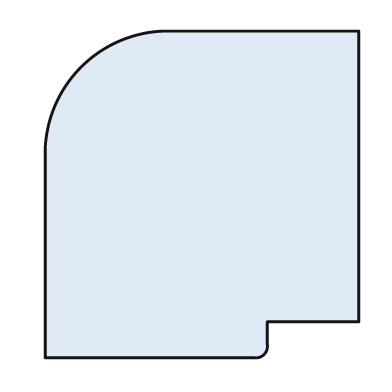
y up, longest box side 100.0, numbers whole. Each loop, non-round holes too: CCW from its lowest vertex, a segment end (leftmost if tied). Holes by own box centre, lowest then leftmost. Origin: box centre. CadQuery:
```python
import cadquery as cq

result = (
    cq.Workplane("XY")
    .moveTo(-48.0, -50.0)
    .lineTo(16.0, -50.0)
    .threePointArc((19.0, -49.0), (20.0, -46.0))
    .lineTo(20.0, -39.0)
    .lineTo(48.0, -39.0)
    .lineTo(48.0, 50.0)
    .lineTo(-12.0, 50.0)
    .threePointArc((-37.0, 39.0), (-48.0, 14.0))
    .close()
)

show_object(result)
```